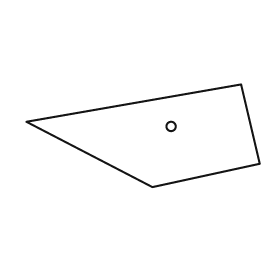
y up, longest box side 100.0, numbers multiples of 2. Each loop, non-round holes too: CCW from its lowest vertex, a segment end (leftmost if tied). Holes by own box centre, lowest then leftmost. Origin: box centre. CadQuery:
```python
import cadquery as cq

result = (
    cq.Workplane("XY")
    .moveTo(4.0, -22.0)
    .lineTo(50.0, -12.0)
    .lineTo(42.0, 22.0)
    .lineTo(-50.0, 6.0)
    .close()
    .moveTo(12.0, 4.0)
    .circle(2.0)
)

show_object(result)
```